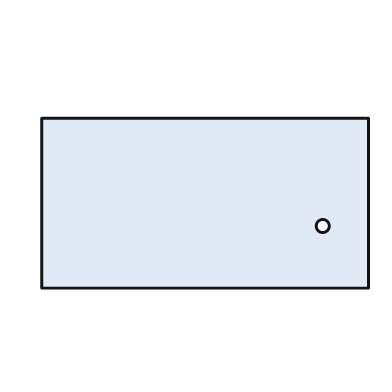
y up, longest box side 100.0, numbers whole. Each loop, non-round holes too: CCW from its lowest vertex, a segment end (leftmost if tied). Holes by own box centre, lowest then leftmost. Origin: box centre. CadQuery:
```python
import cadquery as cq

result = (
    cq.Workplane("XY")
    .moveTo(-50.0, -26.0)
    .lineTo(50.0, -26.0)
    .lineTo(50.0, 26.0)
    .lineTo(-50.0, 26.0)
    .close()
    .moveTo(36.0, -7.0)
    .circle(2.0)
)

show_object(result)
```